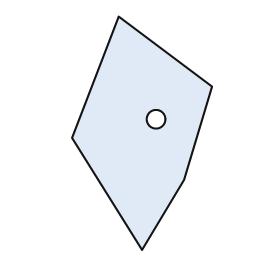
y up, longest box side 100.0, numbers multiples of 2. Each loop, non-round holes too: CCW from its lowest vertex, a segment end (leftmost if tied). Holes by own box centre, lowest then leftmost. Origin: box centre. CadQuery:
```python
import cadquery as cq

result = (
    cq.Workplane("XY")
    .moveTo(0.0, -50.0)
    .lineTo(18.0, -20.0)
    .lineTo(30.0, 20.0)
    .lineTo(-10.0, 50.0)
    .lineTo(-30.0, -2.0)
    .close()
    .moveTo(6.0, 6.0)
    .circle(4.0)
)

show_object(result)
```